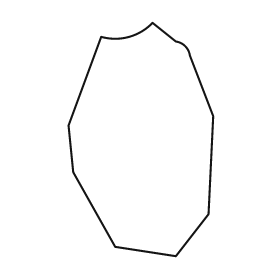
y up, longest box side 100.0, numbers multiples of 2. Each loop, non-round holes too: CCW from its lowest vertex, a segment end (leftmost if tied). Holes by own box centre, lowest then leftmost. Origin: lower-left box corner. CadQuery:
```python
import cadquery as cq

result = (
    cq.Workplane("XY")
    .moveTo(46.0, 0.0)
    .lineTo(60.0, 18.0)
    .lineTo(62.0, 60.0)
    .lineTo(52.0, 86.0)
    .threePointArc((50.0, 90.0), (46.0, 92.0))
    .lineTo(36.0, 100.0)
    .threePointArc((26.0, 94.0), (14.0, 94.0))
    .lineTo(0.0, 56.0)
    .lineTo(2.0, 36.0)
    .lineTo(20.0, 4.0)
    .close()
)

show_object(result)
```